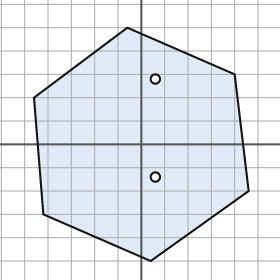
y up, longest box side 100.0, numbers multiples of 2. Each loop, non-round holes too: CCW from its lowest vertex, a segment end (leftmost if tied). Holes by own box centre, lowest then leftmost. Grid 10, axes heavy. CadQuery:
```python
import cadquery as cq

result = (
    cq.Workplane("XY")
    .moveTo(4.0, -50.0)
    .lineTo(46.0, -20.0)
    .lineTo(40.0, 30.0)
    .lineTo(-6.0, 50.0)
    .lineTo(-46.0, 20.0)
    .lineTo(-42.0, -30.0)
    .close()
    .moveTo(6.0, -14.0)
    .circle(2.0)
    .moveTo(6.0, 28.0)
    .circle(2.0)
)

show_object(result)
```